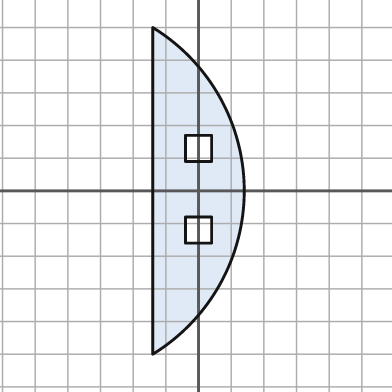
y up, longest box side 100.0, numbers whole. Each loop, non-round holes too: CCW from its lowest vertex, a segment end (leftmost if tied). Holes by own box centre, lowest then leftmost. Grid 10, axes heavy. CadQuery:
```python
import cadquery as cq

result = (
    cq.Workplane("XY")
    .moveTo(-14.0, -50.0)
    .threePointArc((14.0, 0.0), (-14.0, 50.0))
    .close()
    .moveTo(-4.0, -16.0)
    .lineTo(4.0, -16.0)
    .lineTo(4.0, -8.0)
    .lineTo(-4.0, -8.0)
    .close()
    .moveTo(-4.0, 9.0)
    .lineTo(4.0, 9.0)
    .lineTo(4.0, 17.0)
    .lineTo(-4.0, 17.0)
    .close()
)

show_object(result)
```